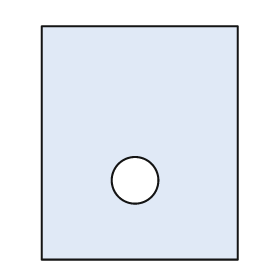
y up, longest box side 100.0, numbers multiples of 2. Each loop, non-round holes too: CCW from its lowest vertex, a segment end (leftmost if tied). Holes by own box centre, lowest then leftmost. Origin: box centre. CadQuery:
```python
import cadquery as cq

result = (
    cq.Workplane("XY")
    .moveTo(-42.0, -50.0)
    .lineTo(42.0, -50.0)
    .lineTo(42.0, 50.0)
    .lineTo(-42.0, 50.0)
    .close()
    .moveTo(-2.0, -16.0)
    .circle(10.0)
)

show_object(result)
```